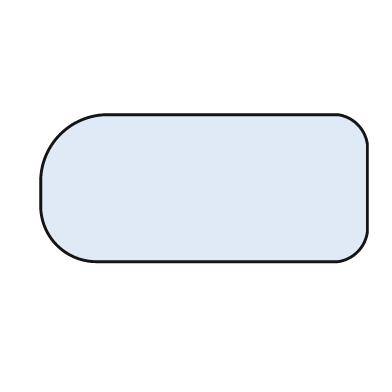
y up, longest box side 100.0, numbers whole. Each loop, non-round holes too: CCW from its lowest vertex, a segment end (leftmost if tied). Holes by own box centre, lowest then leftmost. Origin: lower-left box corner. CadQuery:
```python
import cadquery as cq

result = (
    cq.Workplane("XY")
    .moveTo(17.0, 0.0)
    .lineTo(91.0, 0.0)
    .threePointArc((97.0, 3.0), (100.0, 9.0))
    .lineTo(100.0, 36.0)
    .threePointArc((97.0, 42.0), (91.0, 45.0))
    .lineTo(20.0, 45.0)
    .threePointArc((6.0, 39.0), (0.0, 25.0))
    .lineTo(0.0, 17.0)
    .threePointArc((5.0, 5.0), (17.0, 0.0))
    .close()
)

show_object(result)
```